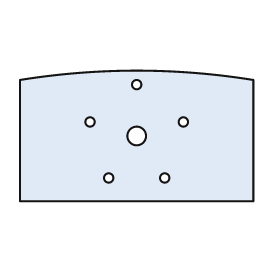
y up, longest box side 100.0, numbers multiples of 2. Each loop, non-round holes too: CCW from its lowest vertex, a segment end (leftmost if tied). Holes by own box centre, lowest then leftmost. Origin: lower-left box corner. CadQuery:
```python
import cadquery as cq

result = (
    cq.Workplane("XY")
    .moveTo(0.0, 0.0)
    .lineTo(100.0, 0.0)
    .lineTo(100.0, 52.0)
    .threePointArc((50.0, 56.0), (0.0, 52.0))
    .close()
    .moveTo(38.0, 10.0)
    .circle(2.0)
    .moveTo(62.0, 10.0)
    .circle(2.0)
    .moveTo(50.0, 28.0)
    .circle(4.0)
    .moveTo(30.0, 34.0)
    .circle(2.0)
    .moveTo(70.0, 34.0)
    .circle(2.0)
    .moveTo(50.0, 50.0)
    .circle(2.0)
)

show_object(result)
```